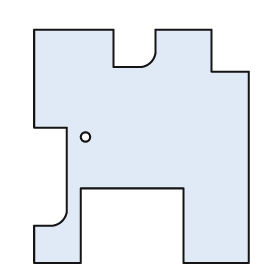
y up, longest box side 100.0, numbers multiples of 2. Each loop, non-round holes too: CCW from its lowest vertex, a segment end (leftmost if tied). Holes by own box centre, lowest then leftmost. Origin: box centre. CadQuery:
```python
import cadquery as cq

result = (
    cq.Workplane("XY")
    .moveTo(-46.0, -50.0)
    .lineTo(-26.0, -50.0)
    .lineTo(-26.0, -18.0)
    .lineTo(18.0, -18.0)
    .lineTo(18.0, -50.0)
    .lineTo(46.0, -50.0)
    .lineTo(46.0, 32.0)
    .lineTo(30.0, 32.0)
    .lineTo(30.0, 50.0)
    .lineTo(6.0, 50.0)
    .lineTo(6.0, 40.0)
    .threePointArc((4.0, 36.0), (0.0, 34.0))
    .lineTo(-12.0, 34.0)
    .lineTo(-12.0, 50.0)
    .lineTo(-46.0, 50.0)
    .lineTo(-46.0, 8.0)
    .lineTo(-32.0, 8.0)
    .lineTo(-32.0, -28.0)
    .threePointArc((-34.0, -32.0), (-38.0, -34.0))
    .lineTo(-46.0, -34.0)
    .close()
    .moveTo(-24.0, 4.0)
    .circle(2.0)
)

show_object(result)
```